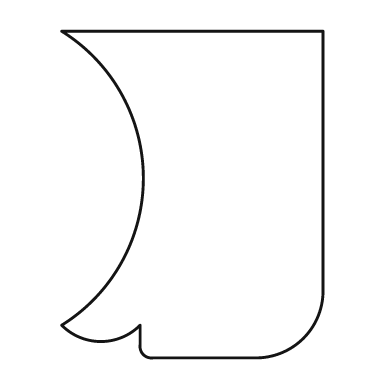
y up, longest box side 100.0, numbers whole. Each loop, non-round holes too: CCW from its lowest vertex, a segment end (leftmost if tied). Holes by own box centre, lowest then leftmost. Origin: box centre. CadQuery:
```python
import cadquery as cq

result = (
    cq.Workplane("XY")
    .moveTo(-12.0, -50.0)
    .lineTo(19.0, -50.0)
    .threePointArc((34.0, -44.0), (40.0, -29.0))
    .lineTo(40.0, 50.0)
    .lineTo(-40.0, 50.0)
    .threePointArc((-15.0, 5.0), (-40.0, -40.0))
    .threePointArc((-28.0, -45.0), (-16.0, -40.0))
    .lineTo(-16.0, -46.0)
    .threePointArc((-15.0, -49.0), (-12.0, -50.0))
    .close()
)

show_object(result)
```